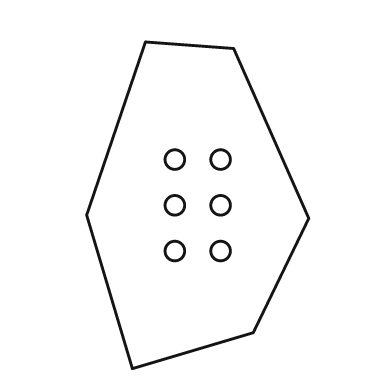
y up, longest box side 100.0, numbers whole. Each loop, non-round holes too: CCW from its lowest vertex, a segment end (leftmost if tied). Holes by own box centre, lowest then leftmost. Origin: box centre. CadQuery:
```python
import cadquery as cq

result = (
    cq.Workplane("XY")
    .moveTo(-20.0, -50.0)
    .lineTo(17.0, -39.0)
    .lineTo(34.0, -4.0)
    .lineTo(11.0, 48.0)
    .lineTo(-16.0, 50.0)
    .lineTo(-34.0, -3.0)
    .close()
    .moveTo(-7.0, -14.0)
    .circle(3.0)
    .moveTo(7.0, -14.0)
    .circle(3.0)
    .moveTo(-7.0, 0.0)
    .circle(3.0)
    .moveTo(7.0, 0.0)
    .circle(3.0)
    .moveTo(-7.0, 14.0)
    .circle(3.0)
    .moveTo(7.0, 14.0)
    .circle(3.0)
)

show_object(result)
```